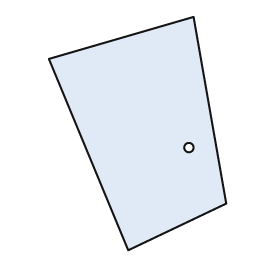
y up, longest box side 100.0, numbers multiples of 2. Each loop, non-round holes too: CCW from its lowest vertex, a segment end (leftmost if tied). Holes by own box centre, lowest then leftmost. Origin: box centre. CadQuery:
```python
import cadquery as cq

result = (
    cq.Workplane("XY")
    .moveTo(-4.0, -50.0)
    .lineTo(38.0, -30.0)
    .lineTo(24.0, 50.0)
    .lineTo(-38.0, 32.0)
    .close()
    .moveTo(22.0, -6.0)
    .circle(2.0)
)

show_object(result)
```